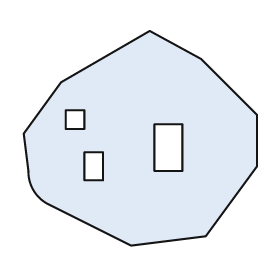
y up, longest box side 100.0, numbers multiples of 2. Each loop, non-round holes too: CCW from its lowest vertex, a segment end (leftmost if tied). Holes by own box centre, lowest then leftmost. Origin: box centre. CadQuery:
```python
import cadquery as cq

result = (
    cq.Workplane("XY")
    .moveTo(-4.0, -46.0)
    .lineTo(28.0, -42.0)
    .lineTo(50.0, -12.0)
    .lineTo(50.0, 10.0)
    .lineTo(26.0, 34.0)
    .lineTo(4.0, 46.0)
    .lineTo(-34.0, 24.0)
    .lineTo(-50.0, 2.0)
    .lineTo(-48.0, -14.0)
    .threePointArc((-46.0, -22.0), (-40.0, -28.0))
    .close()
    .moveTo(-24.0, -18.0)
    .lineTo(-16.0, -18.0)
    .lineTo(-16.0, -6.0)
    .lineTo(-24.0, -6.0)
    .close()
    .moveTo(6.0, -14.0)
    .lineTo(18.0, -14.0)
    .lineTo(18.0, 6.0)
    .lineTo(6.0, 6.0)
    .close()
    .moveTo(-32.0, 4.0)
    .lineTo(-24.0, 4.0)
    .lineTo(-24.0, 12.0)
    .lineTo(-32.0, 12.0)
    .close()
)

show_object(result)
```